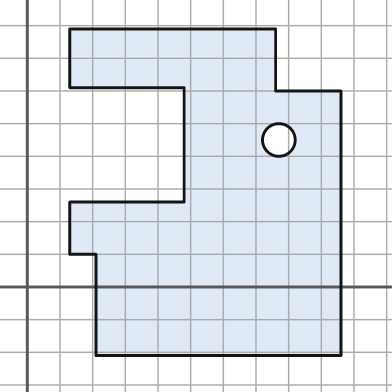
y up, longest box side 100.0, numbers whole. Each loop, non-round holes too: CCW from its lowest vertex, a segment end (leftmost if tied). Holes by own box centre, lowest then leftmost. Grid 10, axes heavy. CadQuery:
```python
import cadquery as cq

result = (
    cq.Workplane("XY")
    .moveTo(21.0, -21.0)
    .lineTo(96.0, -21.0)
    .lineTo(96.0, 60.0)
    .lineTo(76.0, 60.0)
    .lineTo(76.0, 79.0)
    .lineTo(13.0, 79.0)
    .lineTo(13.0, 61.0)
    .lineTo(48.0, 61.0)
    .lineTo(48.0, 26.0)
    .lineTo(13.0, 26.0)
    .lineTo(13.0, 10.0)
    .lineTo(21.0, 10.0)
    .close()
    .moveTo(77.0, 45.0)
    .circle(5.0)
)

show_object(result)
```